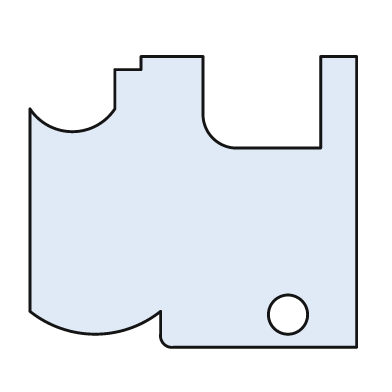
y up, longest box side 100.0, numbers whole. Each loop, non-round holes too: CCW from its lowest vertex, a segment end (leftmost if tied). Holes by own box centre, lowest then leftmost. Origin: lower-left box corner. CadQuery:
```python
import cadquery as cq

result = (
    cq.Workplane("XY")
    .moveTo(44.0, 0.0)
    .lineTo(100.0, 0.0)
    .lineTo(100.0, 89.0)
    .lineTo(89.0, 89.0)
    .lineTo(89.0, 61.0)
    .lineTo(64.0, 61.0)
    .threePointArc((56.0, 64.0), (53.0, 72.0))
    .lineTo(53.0, 89.0)
    .lineTo(34.0, 89.0)
    .lineTo(34.0, 85.0)
    .lineTo(26.0, 85.0)
    .lineTo(26.0, 73.0)
    .threePointArc((13.0, 66.0), (0.0, 73.0))
    .lineTo(0.0, 11.0)
    .threePointArc((20.0, 4.0), (40.0, 11.0))
    .lineTo(40.0, 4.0)
    .threePointArc((41.0, 1.0), (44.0, 0.0))
    .close()
    .moveTo(79.0, 10.0)
    .circle(6.0)
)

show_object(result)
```